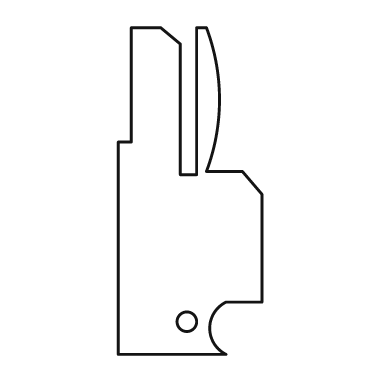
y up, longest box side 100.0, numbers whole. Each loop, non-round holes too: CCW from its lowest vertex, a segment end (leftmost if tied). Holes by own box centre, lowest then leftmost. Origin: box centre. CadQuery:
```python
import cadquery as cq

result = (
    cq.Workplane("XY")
    .moveTo(-22.0, -50.0)
    .lineTo(11.0, -50.0)
    .threePointArc((6.0, -42.0), (11.0, -34.0))
    .lineTo(22.0, -34.0)
    .lineTo(22.0, -1.0)
    .lineTo(16.0, 6.0)
    .lineTo(5.0, 6.0)
    .threePointArc((9.0, 28.0), (5.0, 50.0))
    .lineTo(2.0, 50.0)
    .lineTo(2.0, 5.0)
    .lineTo(-3.0, 5.0)
    .lineTo(-3.0, 45.0)
    .lineTo(-9.0, 50.0)
    .lineTo(-18.0, 50.0)
    .lineTo(-18.0, 15.0)
    .lineTo(-22.0, 15.0)
    .close()
    .moveTo(-1.0, -40.0)
    .circle(3.0)
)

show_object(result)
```